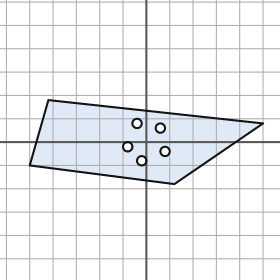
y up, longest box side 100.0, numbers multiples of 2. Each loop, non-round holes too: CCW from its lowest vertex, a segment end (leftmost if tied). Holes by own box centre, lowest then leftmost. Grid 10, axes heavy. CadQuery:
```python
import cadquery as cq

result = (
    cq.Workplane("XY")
    .moveTo(12.0, -18.0)
    .lineTo(50.0, 8.0)
    .lineTo(-42.0, 18.0)
    .lineTo(-50.0, -10.0)
    .close()
    .moveTo(-2.0, -8.0)
    .circle(2.0)
    .moveTo(8.0, -4.0)
    .circle(2.0)
    .moveTo(-8.0, -2.0)
    .circle(2.0)
    .moveTo(6.0, 6.0)
    .circle(2.0)
    .moveTo(-4.0, 8.0)
    .circle(2.0)
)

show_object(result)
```